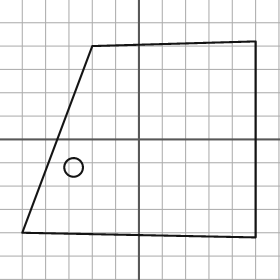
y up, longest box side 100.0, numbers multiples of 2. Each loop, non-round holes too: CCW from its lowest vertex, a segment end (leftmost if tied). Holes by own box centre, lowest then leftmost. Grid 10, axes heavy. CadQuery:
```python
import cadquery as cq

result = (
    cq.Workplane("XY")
    .moveTo(50.0, -42.0)
    .lineTo(50.0, 42.0)
    .lineTo(-20.0, 40.0)
    .lineTo(-50.0, -40.0)
    .close()
    .moveTo(-28.0, -12.0)
    .circle(4.0)
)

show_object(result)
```